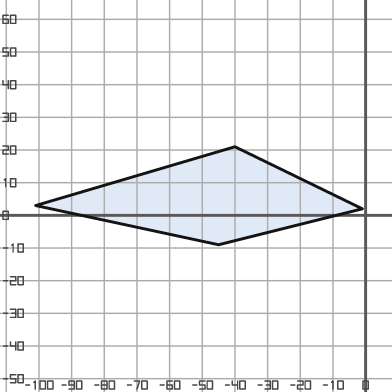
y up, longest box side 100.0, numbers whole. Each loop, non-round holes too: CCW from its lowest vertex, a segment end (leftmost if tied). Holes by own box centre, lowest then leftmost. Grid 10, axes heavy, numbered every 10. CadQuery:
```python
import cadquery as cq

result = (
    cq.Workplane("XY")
    .moveTo(-45.0, -9.0)
    .lineTo(-1.0, 2.0)
    .lineTo(-40.0, 21.0)
    .lineTo(-101.0, 3.0)
    .close()
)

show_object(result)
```